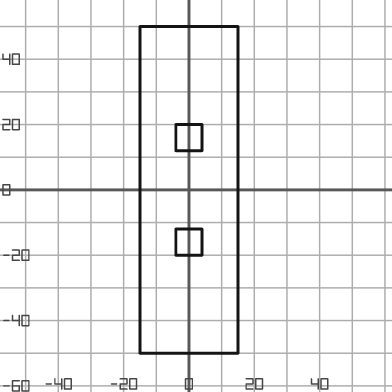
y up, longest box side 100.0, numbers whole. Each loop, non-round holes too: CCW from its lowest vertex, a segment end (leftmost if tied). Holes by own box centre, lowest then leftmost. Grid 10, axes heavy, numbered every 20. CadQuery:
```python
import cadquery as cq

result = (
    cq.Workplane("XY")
    .moveTo(-15.0, -50.0)
    .lineTo(15.0, -50.0)
    .lineTo(15.0, 50.0)
    .lineTo(-15.0, 50.0)
    .close()
    .moveTo(-4.0, -20.0)
    .lineTo(4.0, -20.0)
    .lineTo(4.0, -12.0)
    .lineTo(-4.0, -12.0)
    .close()
    .moveTo(-4.0, 12.0)
    .lineTo(4.0, 12.0)
    .lineTo(4.0, 20.0)
    .lineTo(-4.0, 20.0)
    .close()
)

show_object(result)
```